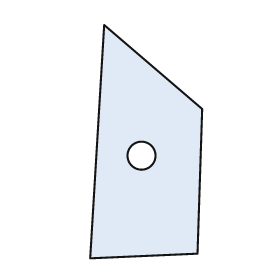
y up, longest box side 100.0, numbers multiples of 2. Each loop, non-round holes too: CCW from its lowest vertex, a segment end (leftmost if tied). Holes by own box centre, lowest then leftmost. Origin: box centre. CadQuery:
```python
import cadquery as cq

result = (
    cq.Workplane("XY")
    .moveTo(-24.0, -50.0)
    .lineTo(22.0, -48.0)
    .lineTo(24.0, 14.0)
    .lineTo(-18.0, 50.0)
    .close()
    .moveTo(-2.0, -6.0)
    .circle(6.0)
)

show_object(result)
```